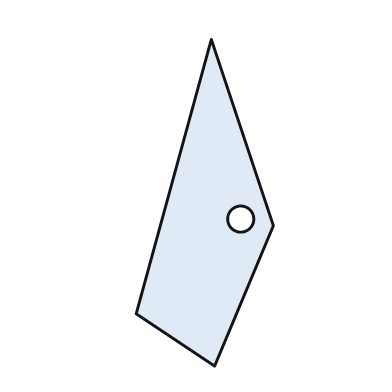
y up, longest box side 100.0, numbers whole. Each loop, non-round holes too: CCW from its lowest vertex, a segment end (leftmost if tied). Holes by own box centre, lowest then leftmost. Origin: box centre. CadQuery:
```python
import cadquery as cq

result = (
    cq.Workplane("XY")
    .moveTo(3.0, -50.0)
    .lineTo(21.0, -7.0)
    .lineTo(2.0, 50.0)
    .lineTo(-21.0, -34.0)
    .close()
    .moveTo(11.0, -5.0)
    .circle(4.0)
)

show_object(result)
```